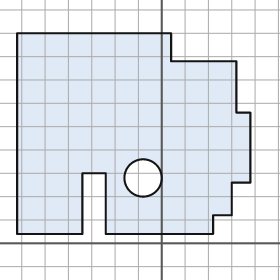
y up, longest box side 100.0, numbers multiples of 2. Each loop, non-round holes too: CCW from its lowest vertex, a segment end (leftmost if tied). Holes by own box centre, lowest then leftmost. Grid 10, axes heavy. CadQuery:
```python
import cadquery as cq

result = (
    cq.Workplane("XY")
    .moveTo(-62.0, 4.0)
    .lineTo(-34.0, 4.0)
    .lineTo(-34.0, 30.0)
    .lineTo(-24.0, 30.0)
    .lineTo(-24.0, 4.0)
    .lineTo(22.0, 4.0)
    .lineTo(22.0, 12.0)
    .lineTo(30.0, 12.0)
    .lineTo(30.0, 26.0)
    .lineTo(38.0, 26.0)
    .lineTo(38.0, 56.0)
    .lineTo(32.0, 56.0)
    .lineTo(32.0, 78.0)
    .lineTo(4.0, 78.0)
    .lineTo(4.0, 90.0)
    .lineTo(-62.0, 90.0)
    .close()
    .moveTo(-8.0, 28.0)
    .circle(8.0)
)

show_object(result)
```